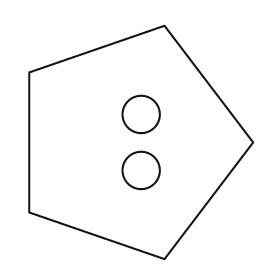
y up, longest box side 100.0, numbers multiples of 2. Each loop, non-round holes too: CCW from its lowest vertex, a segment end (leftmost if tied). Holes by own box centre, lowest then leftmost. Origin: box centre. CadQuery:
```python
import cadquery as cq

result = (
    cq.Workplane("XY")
    .moveTo(10.0, -50.0)
    .lineTo(48.0, 0.0)
    .lineTo(10.0, 50.0)
    .lineTo(-48.0, 30.0)
    .lineTo(-48.0, -30.0)
    .close()
    .moveTo(0.0, -12.0)
    .circle(8.0)
    .moveTo(0.0, 12.0)
    .circle(8.0)
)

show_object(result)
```